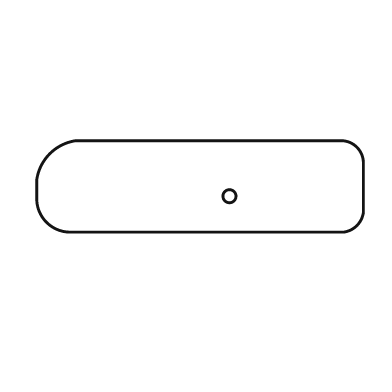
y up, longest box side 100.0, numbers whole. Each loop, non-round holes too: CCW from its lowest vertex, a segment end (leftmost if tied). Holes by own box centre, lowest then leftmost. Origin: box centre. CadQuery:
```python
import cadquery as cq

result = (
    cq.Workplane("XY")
    .moveTo(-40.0, -14.0)
    .lineTo(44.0, -14.0)
    .threePointArc((48.0, -12.0), (50.0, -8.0))
    .lineTo(50.0, 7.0)
    .threePointArc((48.0, 12.0), (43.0, 14.0))
    .lineTo(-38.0, 14.0)
    .threePointArc((-46.0, 10.0), (-50.0, 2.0))
    .lineTo(-50.0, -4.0)
    .threePointArc((-47.0, -11.0), (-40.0, -14.0))
    .close()
    .moveTo(9.0, -3.0)
    .circle(2.0)
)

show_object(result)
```